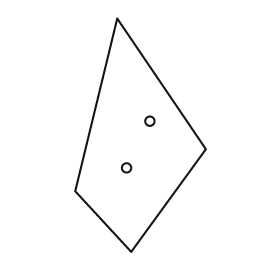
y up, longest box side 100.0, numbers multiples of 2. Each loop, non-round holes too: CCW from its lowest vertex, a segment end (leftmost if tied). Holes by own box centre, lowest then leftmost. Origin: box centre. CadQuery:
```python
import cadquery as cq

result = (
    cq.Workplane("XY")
    .moveTo(-4.0, -50.0)
    .lineTo(28.0, -6.0)
    .lineTo(-10.0, 50.0)
    .lineTo(-28.0, -24.0)
    .close()
    .moveTo(-6.0, -14.0)
    .circle(2.0)
    .moveTo(4.0, 6.0)
    .circle(2.0)
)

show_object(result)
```